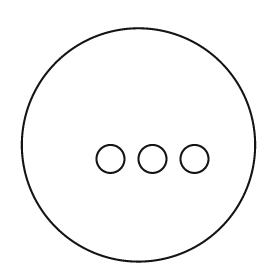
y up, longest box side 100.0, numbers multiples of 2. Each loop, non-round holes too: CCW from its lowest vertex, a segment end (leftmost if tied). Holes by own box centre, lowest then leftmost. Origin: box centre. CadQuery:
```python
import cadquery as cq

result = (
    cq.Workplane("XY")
    .moveTo(0.0, 0.0)
    .circle(50.0)
    .moveTo(-12.0, -6.0)
    .circle(6.0)
    .moveTo(6.0, -6.0)
    .circle(6.0)
    .moveTo(24.0, -6.0)
    .circle(6.0)
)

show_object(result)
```